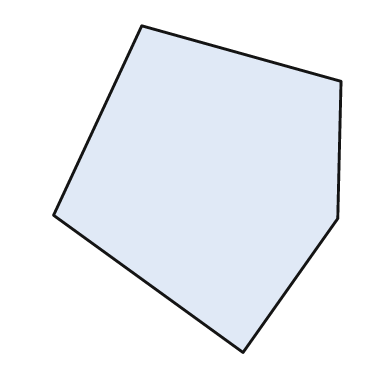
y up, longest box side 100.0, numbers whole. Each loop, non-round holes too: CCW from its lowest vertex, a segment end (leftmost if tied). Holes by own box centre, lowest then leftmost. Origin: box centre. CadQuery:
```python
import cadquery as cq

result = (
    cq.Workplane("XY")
    .moveTo(14.0, -50.0)
    .lineTo(43.0, -9.0)
    .lineTo(44.0, 33.0)
    .lineTo(-17.0, 50.0)
    .lineTo(-44.0, -8.0)
    .close()
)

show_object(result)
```